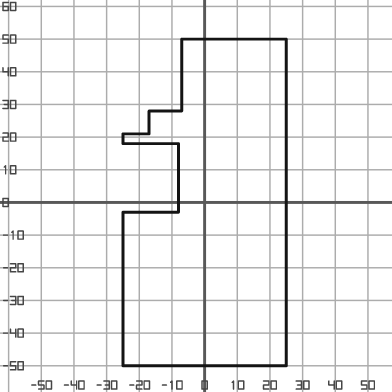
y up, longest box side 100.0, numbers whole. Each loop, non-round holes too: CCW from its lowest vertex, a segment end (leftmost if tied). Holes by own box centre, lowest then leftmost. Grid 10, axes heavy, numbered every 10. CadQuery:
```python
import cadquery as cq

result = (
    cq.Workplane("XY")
    .moveTo(-25.0, -50.0)
    .lineTo(25.0, -50.0)
    .lineTo(25.0, 50.0)
    .lineTo(-7.0, 50.0)
    .lineTo(-7.0, 28.0)
    .lineTo(-17.0, 28.0)
    .lineTo(-17.0, 21.0)
    .lineTo(-25.0, 21.0)
    .lineTo(-25.0, 18.0)
    .lineTo(-8.0, 18.0)
    .lineTo(-8.0, -3.0)
    .lineTo(-25.0, -3.0)
    .close()
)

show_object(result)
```